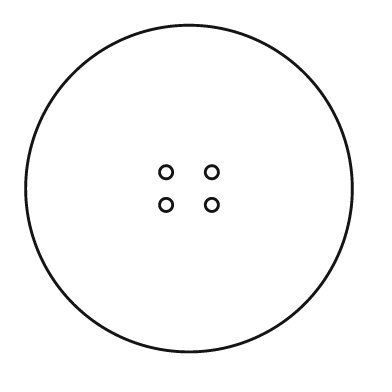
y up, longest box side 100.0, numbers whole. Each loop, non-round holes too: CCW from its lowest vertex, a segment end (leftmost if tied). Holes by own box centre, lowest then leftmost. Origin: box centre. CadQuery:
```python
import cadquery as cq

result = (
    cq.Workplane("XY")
    .moveTo(0.0, 0.0)
    .circle(50.0)
    .moveTo(-7.0, -5.0)
    .circle(2.0)
    .moveTo(7.0, -5.0)
    .circle(2.0)
    .moveTo(-7.0, 5.0)
    .circle(2.0)
    .moveTo(7.0, 5.0)
    .circle(2.0)
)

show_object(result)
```